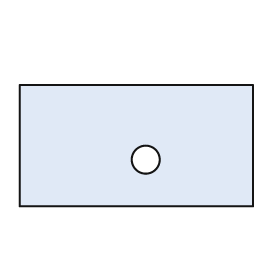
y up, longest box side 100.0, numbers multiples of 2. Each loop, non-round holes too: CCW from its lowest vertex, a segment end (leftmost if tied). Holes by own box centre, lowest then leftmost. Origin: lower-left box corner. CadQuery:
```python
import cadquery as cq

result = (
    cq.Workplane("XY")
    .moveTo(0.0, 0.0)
    .lineTo(100.0, 0.0)
    .lineTo(100.0, 52.0)
    .lineTo(0.0, 52.0)
    .close()
    .moveTo(54.0, 20.0)
    .circle(6.0)
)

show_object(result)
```